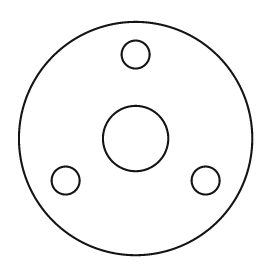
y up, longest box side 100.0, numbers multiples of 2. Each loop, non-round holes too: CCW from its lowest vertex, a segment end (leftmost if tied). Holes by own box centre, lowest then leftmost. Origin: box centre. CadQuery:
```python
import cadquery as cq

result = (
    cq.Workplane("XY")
    .moveTo(0.0, 0.0)
    .circle(50.0)
    .moveTo(-30.0, -18.0)
    .circle(6.0)
    .moveTo(30.0, -18.0)
    .circle(6.0)
    .moveTo(0.0, 0.0)
    .circle(14.0)
    .moveTo(0.0, 36.0)
    .circle(6.0)
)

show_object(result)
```